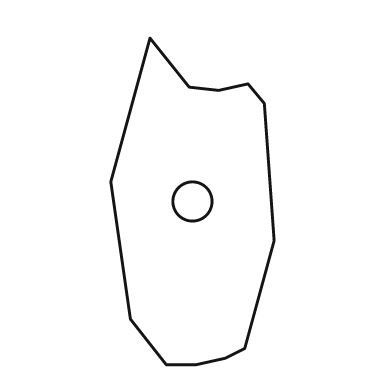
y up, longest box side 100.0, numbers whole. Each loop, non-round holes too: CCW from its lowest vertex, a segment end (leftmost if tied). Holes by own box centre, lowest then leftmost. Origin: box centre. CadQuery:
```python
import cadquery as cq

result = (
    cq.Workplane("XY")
    .moveTo(-8.0, -50.0)
    .lineTo(1.0, -50.0)
    .lineTo(10.0, -48.0)
    .lineTo(16.0, -45.0)
    .lineTo(25.0, -12.0)
    .lineTo(22.0, 30.0)
    .lineTo(17.0, 36.0)
    .lineTo(8.0, 34.0)
    .lineTo(-1.0, 35.0)
    .lineTo(-13.0, 50.0)
    .lineTo(-25.0, 6.0)
    .lineTo(-19.0, -36.0)
    .close()
    .moveTo(0.0, 0.0)
    .circle(6.0)
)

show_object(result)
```